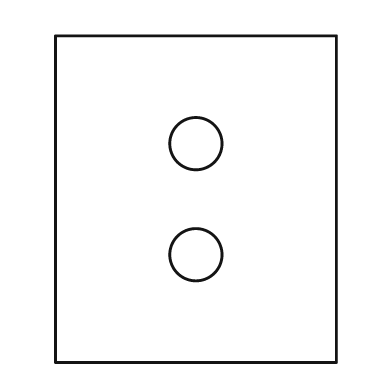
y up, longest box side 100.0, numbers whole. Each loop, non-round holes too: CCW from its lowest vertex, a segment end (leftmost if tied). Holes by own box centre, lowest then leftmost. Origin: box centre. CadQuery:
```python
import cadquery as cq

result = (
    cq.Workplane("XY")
    .moveTo(-43.0, -50.0)
    .lineTo(43.0, -50.0)
    .lineTo(43.0, 50.0)
    .lineTo(-43.0, 50.0)
    .close()
    .moveTo(0.0, -17.0)
    .circle(8.0)
    .moveTo(0.0, 17.0)
    .circle(8.0)
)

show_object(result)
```